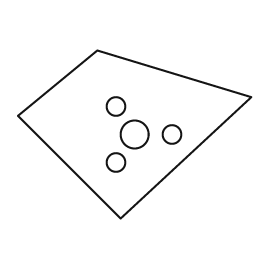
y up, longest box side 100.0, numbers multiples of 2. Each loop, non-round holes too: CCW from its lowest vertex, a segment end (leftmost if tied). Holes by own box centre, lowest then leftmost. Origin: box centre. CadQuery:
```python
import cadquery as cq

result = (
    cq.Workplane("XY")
    .moveTo(-6.0, -36.0)
    .lineTo(50.0, 16.0)
    .lineTo(-16.0, 36.0)
    .lineTo(-50.0, 8.0)
    .close()
    .moveTo(-8.0, -12.0)
    .circle(4.0)
    .moveTo(0.0, 0.0)
    .circle(6.0)
    .moveTo(16.0, 0.0)
    .circle(4.0)
    .moveTo(-8.0, 12.0)
    .circle(4.0)
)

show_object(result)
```